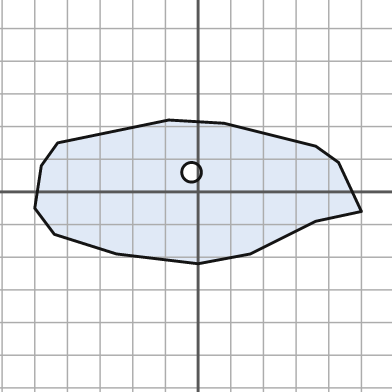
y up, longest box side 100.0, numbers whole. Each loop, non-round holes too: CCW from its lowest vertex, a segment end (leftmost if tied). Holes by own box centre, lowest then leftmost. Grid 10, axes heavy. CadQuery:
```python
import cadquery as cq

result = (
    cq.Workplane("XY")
    .moveTo(0.0, -22.0)
    .lineTo(16.0, -19.0)
    .lineTo(36.0, -9.0)
    .lineTo(50.0, -6.0)
    .lineTo(43.0, 9.0)
    .lineTo(36.0, 14.0)
    .lineTo(8.0, 21.0)
    .lineTo(-9.0, 22.0)
    .lineTo(-43.0, 15.0)
    .lineTo(-48.0, 8.0)
    .lineTo(-50.0, -5.0)
    .lineTo(-44.0, -13.0)
    .lineTo(-25.0, -19.0)
    .close()
    .moveTo(-2.0, 6.0)
    .circle(3.0)
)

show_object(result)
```